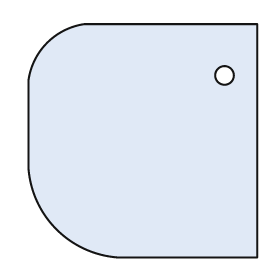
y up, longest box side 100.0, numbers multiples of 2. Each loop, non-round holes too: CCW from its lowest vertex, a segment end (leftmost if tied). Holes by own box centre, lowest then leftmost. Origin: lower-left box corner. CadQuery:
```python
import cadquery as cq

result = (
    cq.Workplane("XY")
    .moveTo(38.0, 0.0)
    .lineTo(98.0, 0.0)
    .lineTo(98.0, 100.0)
    .lineTo(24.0, 100.0)
    .threePointArc((8.0, 92.0), (0.0, 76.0))
    .lineTo(0.0, 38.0)
    .threePointArc((12.0, 12.0), (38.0, 0.0))
    .close()
    .moveTo(84.0, 78.0)
    .circle(4.0)
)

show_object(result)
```